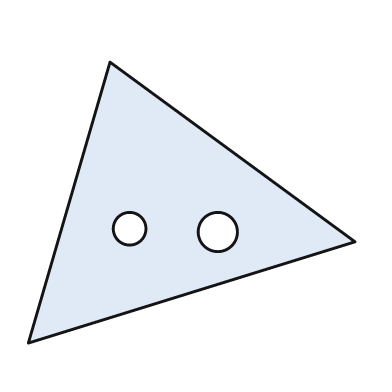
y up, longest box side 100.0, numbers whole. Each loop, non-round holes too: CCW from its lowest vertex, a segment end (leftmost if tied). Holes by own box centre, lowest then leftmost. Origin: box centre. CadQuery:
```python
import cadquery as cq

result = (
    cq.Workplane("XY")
    .moveTo(-50.0, -43.0)
    .lineTo(50.0, -12.0)
    .lineTo(-25.0, 43.0)
    .close()
    .moveTo(8.0, -9.0)
    .circle(6.0)
    .moveTo(-19.0, -8.0)
    .circle(5.0)
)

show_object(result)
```